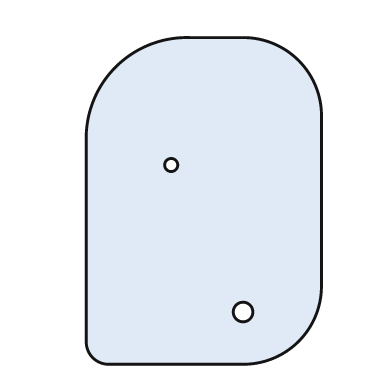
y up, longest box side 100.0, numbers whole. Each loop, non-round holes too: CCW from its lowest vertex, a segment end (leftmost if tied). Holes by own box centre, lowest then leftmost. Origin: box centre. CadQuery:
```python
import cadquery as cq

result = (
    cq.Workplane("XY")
    .moveTo(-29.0, -50.0)
    .lineTo(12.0, -50.0)
    .threePointArc((29.0, -43.0), (36.0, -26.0))
    .lineTo(36.0, 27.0)
    .threePointArc((29.0, 43.0), (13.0, 50.0))
    .lineTo(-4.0, 50.0)
    .threePointArc((-27.0, 41.0), (-36.0, 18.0))
    .lineTo(-36.0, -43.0)
    .threePointArc((-34.0, -48.0), (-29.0, -50.0))
    .close()
    .moveTo(12.0, -34.0)
    .circle(3.0)
    .moveTo(-10.0, 11.0)
    .circle(2.0)
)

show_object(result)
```